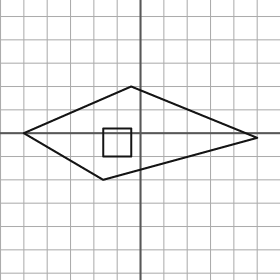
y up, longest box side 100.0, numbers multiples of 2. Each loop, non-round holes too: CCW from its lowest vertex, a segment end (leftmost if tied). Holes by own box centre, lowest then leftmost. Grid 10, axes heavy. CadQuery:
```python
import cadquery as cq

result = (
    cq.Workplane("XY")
    .moveTo(-16.0, -20.0)
    .lineTo(50.0, -2.0)
    .lineTo(-4.0, 20.0)
    .lineTo(-50.0, 0.0)
    .close()
    .moveTo(-16.0, -10.0)
    .lineTo(-4.0, -10.0)
    .lineTo(-4.0, 2.0)
    .lineTo(-16.0, 2.0)
    .close()
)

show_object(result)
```